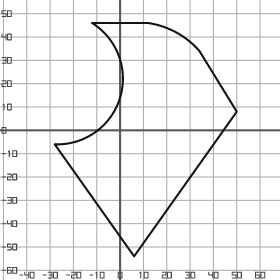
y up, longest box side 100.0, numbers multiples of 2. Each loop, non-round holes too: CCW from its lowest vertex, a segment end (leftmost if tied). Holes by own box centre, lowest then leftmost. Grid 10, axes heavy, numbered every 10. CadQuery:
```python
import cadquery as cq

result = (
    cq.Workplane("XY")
    .moveTo(6.0, -54.0)
    .lineTo(50.0, 8.0)
    .lineTo(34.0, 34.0)
    .threePointArc((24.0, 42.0), (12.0, 46.0))
    .lineTo(-12.0, 46.0)
    .threePointArc((0.0, 14.0), (-28.0, -6.0))
    .close()
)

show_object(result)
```